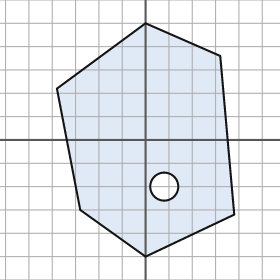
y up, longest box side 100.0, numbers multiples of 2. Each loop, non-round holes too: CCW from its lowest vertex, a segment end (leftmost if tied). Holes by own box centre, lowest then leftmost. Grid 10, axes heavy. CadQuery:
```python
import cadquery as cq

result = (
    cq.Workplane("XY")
    .moveTo(0.0, -50.0)
    .lineTo(38.0, -32.0)
    .lineTo(32.0, 36.0)
    .lineTo(0.0, 50.0)
    .lineTo(-38.0, 22.0)
    .lineTo(-28.0, -30.0)
    .close()
    .moveTo(8.0, -20.0)
    .circle(6.0)
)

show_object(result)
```